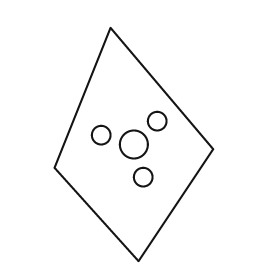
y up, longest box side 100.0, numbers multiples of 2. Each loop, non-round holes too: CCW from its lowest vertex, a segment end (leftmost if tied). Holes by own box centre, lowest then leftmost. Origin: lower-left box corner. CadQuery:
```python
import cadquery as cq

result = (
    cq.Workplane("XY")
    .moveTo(36.0, 0.0)
    .lineTo(68.0, 48.0)
    .lineTo(24.0, 100.0)
    .lineTo(0.0, 40.0)
    .close()
    .moveTo(38.0, 36.0)
    .circle(4.0)
    .moveTo(34.0, 50.0)
    .circle(6.0)
    .moveTo(20.0, 54.0)
    .circle(4.0)
    .moveTo(44.0, 60.0)
    .circle(4.0)
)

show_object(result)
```